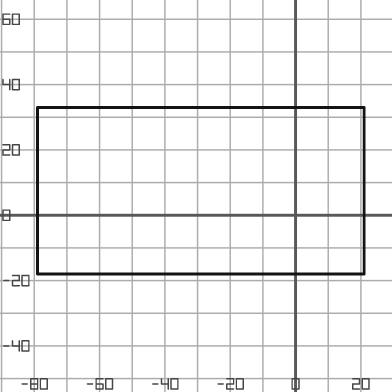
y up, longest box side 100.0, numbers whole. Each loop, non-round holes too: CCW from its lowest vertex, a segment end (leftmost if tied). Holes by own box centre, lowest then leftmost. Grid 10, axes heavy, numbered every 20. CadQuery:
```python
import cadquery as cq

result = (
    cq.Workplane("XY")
    .moveTo(-79.0, -18.0)
    .lineTo(21.0, -18.0)
    .lineTo(21.0, 33.0)
    .lineTo(-79.0, 33.0)
    .close()
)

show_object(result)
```